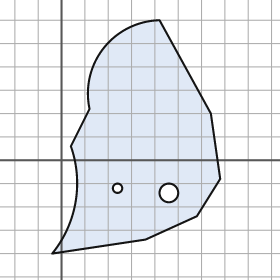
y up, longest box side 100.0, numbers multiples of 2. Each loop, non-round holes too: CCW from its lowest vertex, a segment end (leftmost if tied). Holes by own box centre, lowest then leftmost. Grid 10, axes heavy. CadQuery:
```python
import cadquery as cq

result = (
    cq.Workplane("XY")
    .moveTo(-4.0, -40.0)
    .lineTo(36.0, -34.0)
    .lineTo(58.0, -24.0)
    .lineTo(68.0, -8.0)
    .lineTo(64.0, 20.0)
    .lineTo(42.0, 60.0)
    .threePointArc((18.0, 48.0), (12.0, 22.0))
    .lineTo(4.0, 6.0)
    .threePointArc((6.0, -18.0), (-4.0, -40.0))
    .close()
    .moveTo(46.0, -14.0)
    .circle(4.0)
    .moveTo(24.0, -12.0)
    .circle(2.0)
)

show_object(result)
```